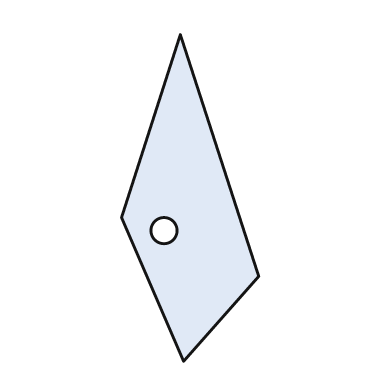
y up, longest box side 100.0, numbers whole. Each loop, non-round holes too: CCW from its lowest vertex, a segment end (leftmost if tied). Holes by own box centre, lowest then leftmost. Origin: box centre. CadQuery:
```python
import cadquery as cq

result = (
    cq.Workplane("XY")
    .moveTo(-2.0, -50.0)
    .lineTo(21.0, -24.0)
    .lineTo(-3.0, 50.0)
    .lineTo(-21.0, -6.0)
    .close()
    .moveTo(-8.0, -10.0)
    .circle(4.0)
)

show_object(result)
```